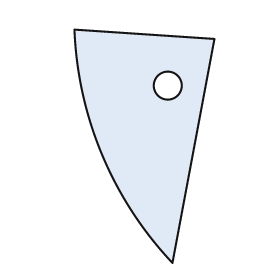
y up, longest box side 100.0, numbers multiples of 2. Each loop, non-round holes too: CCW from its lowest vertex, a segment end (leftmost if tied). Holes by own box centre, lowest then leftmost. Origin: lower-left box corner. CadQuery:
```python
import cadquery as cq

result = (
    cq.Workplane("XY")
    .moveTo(42.0, 0.0)
    .lineTo(60.0, 96.0)
    .lineTo(0.0, 100.0)
    .threePointArc((12.0, 46.0), (42.0, 0.0))
    .close()
    .moveTo(40.0, 76.0)
    .circle(6.0)
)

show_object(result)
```